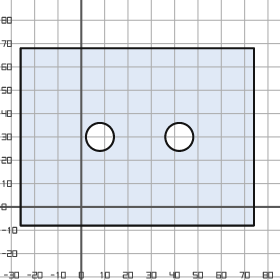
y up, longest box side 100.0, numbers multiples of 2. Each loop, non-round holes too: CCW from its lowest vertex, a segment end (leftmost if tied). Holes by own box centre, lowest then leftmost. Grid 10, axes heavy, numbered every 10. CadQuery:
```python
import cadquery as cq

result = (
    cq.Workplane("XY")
    .moveTo(-26.0, -8.0)
    .lineTo(74.0, -8.0)
    .lineTo(74.0, 68.0)
    .lineTo(-26.0, 68.0)
    .close()
    .moveTo(8.0, 30.0)
    .circle(6.0)
    .moveTo(42.0, 30.0)
    .circle(6.0)
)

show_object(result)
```